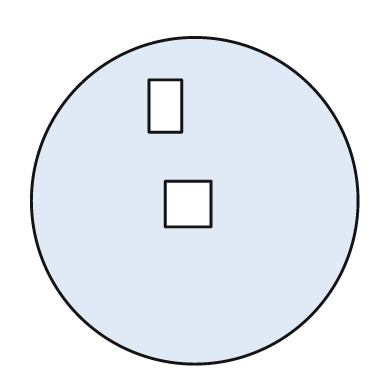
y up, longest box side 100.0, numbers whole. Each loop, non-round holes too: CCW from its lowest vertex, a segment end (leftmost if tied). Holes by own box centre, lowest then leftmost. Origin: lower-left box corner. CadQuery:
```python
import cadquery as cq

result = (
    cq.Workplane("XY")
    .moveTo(50.0, 50.0)
    .circle(50.0)
    .moveTo(41.0, 42.0)
    .lineTo(55.0, 42.0)
    .lineTo(55.0, 56.0)
    .lineTo(41.0, 56.0)
    .close()
    .moveTo(36.0, 71.0)
    .lineTo(46.0, 71.0)
    .lineTo(46.0, 87.0)
    .lineTo(36.0, 87.0)
    .close()
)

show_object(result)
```